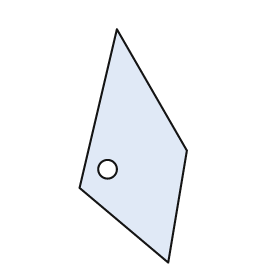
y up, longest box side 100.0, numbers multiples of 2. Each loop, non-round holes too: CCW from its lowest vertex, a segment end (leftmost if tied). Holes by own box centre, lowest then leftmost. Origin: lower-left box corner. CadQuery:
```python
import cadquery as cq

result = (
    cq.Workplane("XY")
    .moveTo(38.0, 0.0)
    .lineTo(46.0, 48.0)
    .lineTo(16.0, 100.0)
    .lineTo(0.0, 32.0)
    .close()
    .moveTo(12.0, 40.0)
    .circle(4.0)
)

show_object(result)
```